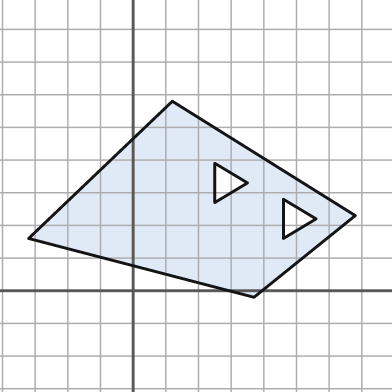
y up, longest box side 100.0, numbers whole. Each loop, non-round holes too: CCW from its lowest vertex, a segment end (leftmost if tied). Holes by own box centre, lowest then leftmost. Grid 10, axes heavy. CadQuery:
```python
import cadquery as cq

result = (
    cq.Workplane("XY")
    .moveTo(37.0, -2.0)
    .lineTo(68.0, 23.0)
    .lineTo(12.0, 58.0)
    .lineTo(-32.0, 16.0)
    .close()
    .moveTo(46.0, 16.0)
    .lineTo(56.0, 22.0)
    .lineTo(46.0, 28.0)
    .close()
    .moveTo(25.0, 27.0)
    .lineTo(35.0, 33.0)
    .lineTo(25.0, 39.0)
    .close()
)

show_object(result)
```